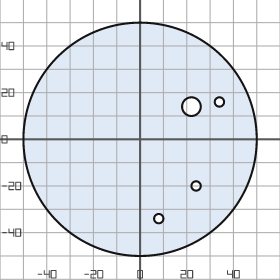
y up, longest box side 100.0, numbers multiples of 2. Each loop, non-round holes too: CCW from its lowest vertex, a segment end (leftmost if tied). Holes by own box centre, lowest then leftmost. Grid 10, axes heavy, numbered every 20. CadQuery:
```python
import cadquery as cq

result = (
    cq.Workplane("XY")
    .moveTo(0.0, 0.0)
    .circle(50.0)
    .moveTo(8.0, -34.0)
    .circle(2.0)
    .moveTo(24.0, -20.0)
    .circle(2.0)
    .moveTo(22.0, 14.0)
    .circle(4.0)
    .moveTo(34.0, 16.0)
    .circle(2.0)
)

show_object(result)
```